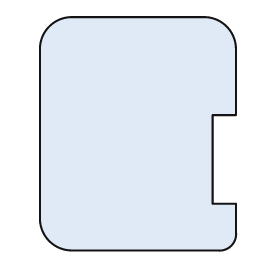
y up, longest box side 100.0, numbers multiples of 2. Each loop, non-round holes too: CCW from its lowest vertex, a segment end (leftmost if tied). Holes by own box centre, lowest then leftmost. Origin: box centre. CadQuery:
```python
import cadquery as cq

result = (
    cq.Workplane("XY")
    .moveTo(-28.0, -50.0)
    .lineTo(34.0, -50.0)
    .threePointArc((40.0, -48.0), (42.0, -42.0))
    .lineTo(42.0, -30.0)
    .lineTo(32.0, -30.0)
    .lineTo(32.0, 8.0)
    .lineTo(42.0, 8.0)
    .lineTo(42.0, 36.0)
    .threePointArc((38.0, 46.0), (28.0, 50.0))
    .lineTo(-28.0, 50.0)
    .threePointArc((-38.0, 46.0), (-42.0, 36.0))
    .lineTo(-42.0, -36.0)
    .threePointArc((-38.0, -46.0), (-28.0, -50.0))
    .close()
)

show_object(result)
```